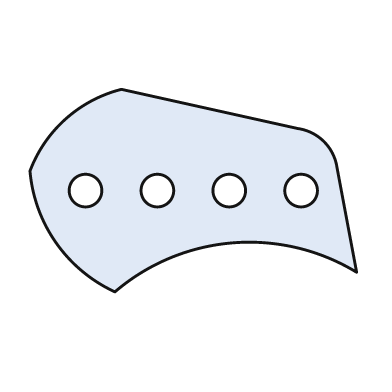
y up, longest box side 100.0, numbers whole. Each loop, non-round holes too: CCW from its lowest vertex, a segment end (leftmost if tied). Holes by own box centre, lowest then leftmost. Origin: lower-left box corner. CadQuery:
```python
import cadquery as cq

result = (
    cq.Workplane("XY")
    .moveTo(26.0, 0.0)
    .threePointArc((62.0, 15.0), (100.0, 6.0))
    .lineTo(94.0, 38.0)
    .threePointArc((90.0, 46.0), (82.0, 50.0))
    .lineTo(28.0, 62.0)
    .threePointArc((11.0, 53.0), (0.0, 37.0))
    .threePointArc((8.0, 15.0), (26.0, 0.0))
    .close()
    .moveTo(17.0, 31.0)
    .circle(5.0)
    .moveTo(39.0, 31.0)
    .circle(5.0)
    .moveTo(61.0, 31.0)
    .circle(5.0)
    .moveTo(83.0, 31.0)
    .circle(5.0)
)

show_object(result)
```